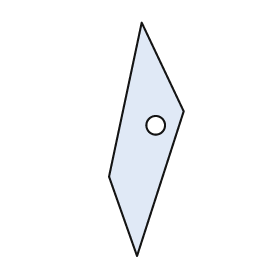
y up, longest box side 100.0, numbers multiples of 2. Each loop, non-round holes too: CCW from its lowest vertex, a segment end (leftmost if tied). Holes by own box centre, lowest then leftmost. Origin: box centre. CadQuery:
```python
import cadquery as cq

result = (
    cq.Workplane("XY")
    .moveTo(-4.0, -50.0)
    .lineTo(16.0, 12.0)
    .lineTo(-2.0, 50.0)
    .lineTo(-16.0, -16.0)
    .close()
    .moveTo(4.0, 6.0)
    .circle(4.0)
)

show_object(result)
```